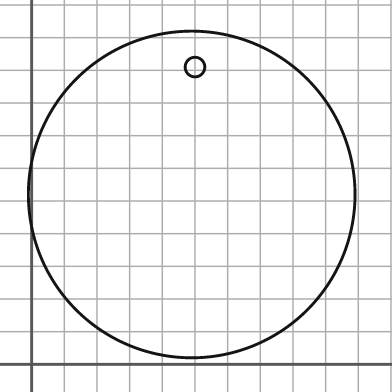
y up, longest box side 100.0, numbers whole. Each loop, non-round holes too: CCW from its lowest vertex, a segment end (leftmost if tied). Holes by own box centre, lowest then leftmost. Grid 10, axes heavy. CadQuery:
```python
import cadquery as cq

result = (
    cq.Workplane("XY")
    .moveTo(49.0, 52.0)
    .circle(50.0)
    .moveTo(50.0, 91.0)
    .circle(3.0)
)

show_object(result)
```